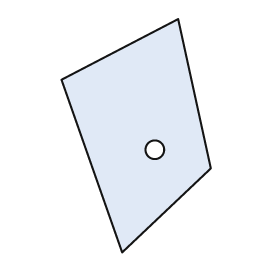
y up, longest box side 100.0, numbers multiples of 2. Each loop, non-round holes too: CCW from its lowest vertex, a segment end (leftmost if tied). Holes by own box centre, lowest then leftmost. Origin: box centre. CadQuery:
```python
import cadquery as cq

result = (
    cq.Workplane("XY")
    .moveTo(-6.0, -50.0)
    .lineTo(32.0, -14.0)
    .lineTo(18.0, 50.0)
    .lineTo(-32.0, 24.0)
    .close()
    .moveTo(8.0, -6.0)
    .circle(4.0)
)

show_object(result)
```